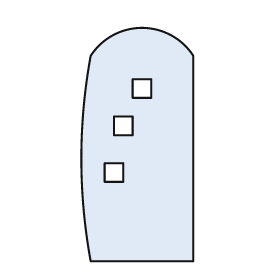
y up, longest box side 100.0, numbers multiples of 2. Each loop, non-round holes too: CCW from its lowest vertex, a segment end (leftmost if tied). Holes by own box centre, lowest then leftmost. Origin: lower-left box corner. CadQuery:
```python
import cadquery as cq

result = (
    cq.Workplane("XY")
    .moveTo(4.0, 0.0)
    .lineTo(48.0, 0.0)
    .lineTo(48.0, 88.0)
    .threePointArc((26.0, 100.0), (4.0, 88.0))
    .threePointArc((0.0, 44.0), (4.0, 0.0))
    .close()
    .moveTo(10.0, 34.0)
    .lineTo(18.0, 34.0)
    .lineTo(18.0, 42.0)
    .lineTo(10.0, 42.0)
    .close()
    .moveTo(14.0, 54.0)
    .lineTo(22.0, 54.0)
    .lineTo(22.0, 62.0)
    .lineTo(14.0, 62.0)
    .close()
    .moveTo(22.0, 70.0)
    .lineTo(30.0, 70.0)
    .lineTo(30.0, 78.0)
    .lineTo(22.0, 78.0)
    .close()
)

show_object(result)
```